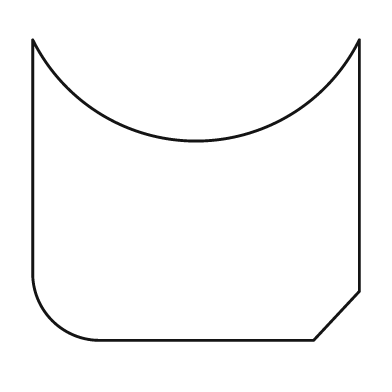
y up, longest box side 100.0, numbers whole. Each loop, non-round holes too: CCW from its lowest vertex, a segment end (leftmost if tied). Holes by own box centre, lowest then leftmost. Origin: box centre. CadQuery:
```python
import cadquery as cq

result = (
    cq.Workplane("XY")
    .moveTo(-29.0, -46.0)
    .lineTo(36.0, -46.0)
    .lineTo(50.0, -31.0)
    .lineTo(50.0, 46.0)
    .threePointArc((0.0, 15.0), (-50.0, 46.0))
    .lineTo(-50.0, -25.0)
    .threePointArc((-44.0, -40.0), (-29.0, -46.0))
    .close()
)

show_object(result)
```